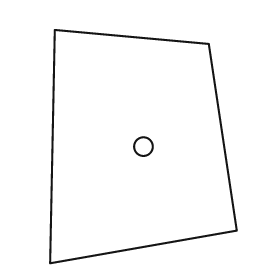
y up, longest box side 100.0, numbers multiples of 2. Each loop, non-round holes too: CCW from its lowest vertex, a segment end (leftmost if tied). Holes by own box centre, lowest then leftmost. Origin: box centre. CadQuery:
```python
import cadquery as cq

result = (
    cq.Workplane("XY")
    .moveTo(-40.0, -50.0)
    .lineTo(40.0, -36.0)
    .lineTo(28.0, 44.0)
    .lineTo(-38.0, 50.0)
    .close()
    .moveTo(0.0, 0.0)
    .circle(4.0)
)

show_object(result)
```